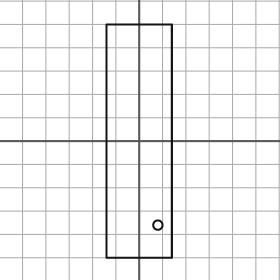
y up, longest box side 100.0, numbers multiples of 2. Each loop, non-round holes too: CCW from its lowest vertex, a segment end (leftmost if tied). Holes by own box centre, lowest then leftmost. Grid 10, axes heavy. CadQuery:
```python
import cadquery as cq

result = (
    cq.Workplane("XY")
    .moveTo(-14.0, -50.0)
    .lineTo(14.0, -50.0)
    .lineTo(14.0, 50.0)
    .lineTo(-14.0, 50.0)
    .close()
    .moveTo(8.0, -36.0)
    .circle(2.0)
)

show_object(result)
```